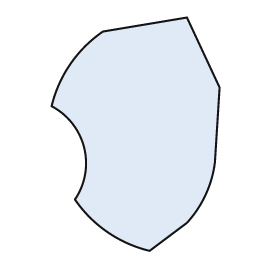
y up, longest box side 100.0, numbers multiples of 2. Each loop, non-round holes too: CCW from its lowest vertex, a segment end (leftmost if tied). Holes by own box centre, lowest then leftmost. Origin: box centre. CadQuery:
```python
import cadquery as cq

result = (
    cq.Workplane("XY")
    .moveTo(6.0, -50.0)
    .lineTo(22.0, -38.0)
    .threePointArc((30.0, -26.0), (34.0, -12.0))
    .lineTo(36.0, 20.0)
    .lineTo(22.0, 50.0)
    .lineTo(-14.0, 44.0)
    .threePointArc((-28.0, 30.0), (-36.0, 12.0))
    .threePointArc((-22.0, -6.0), (-26.0, -28.0))
    .threePointArc((-12.0, -42.0), (6.0, -50.0))
    .close()
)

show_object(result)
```